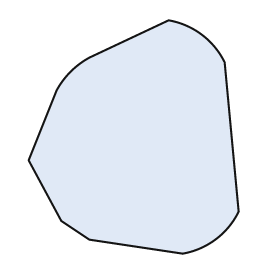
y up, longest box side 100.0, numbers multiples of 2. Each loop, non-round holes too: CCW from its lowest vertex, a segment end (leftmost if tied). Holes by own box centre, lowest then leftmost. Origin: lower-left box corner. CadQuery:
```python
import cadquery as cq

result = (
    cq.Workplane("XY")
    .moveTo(66.0, 0.0)
    .threePointArc((80.0, 6.0), (90.0, 18.0))
    .lineTo(84.0, 82.0)
    .threePointArc((74.0, 94.0), (60.0, 100.0))
    .lineTo(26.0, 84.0)
    .threePointArc((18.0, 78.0), (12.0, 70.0))
    .lineTo(0.0, 40.0)
    .lineTo(14.0, 14.0)
    .lineTo(26.0, 6.0)
    .close()
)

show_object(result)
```